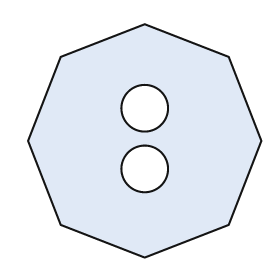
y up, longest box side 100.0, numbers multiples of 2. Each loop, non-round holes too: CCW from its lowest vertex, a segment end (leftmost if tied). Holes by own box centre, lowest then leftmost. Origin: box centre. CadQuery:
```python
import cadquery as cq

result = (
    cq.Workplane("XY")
    .moveTo(0.0, -50.0)
    .lineTo(36.0, -36.0)
    .lineTo(50.0, 0.0)
    .lineTo(36.0, 36.0)
    .lineTo(0.0, 50.0)
    .lineTo(-36.0, 36.0)
    .lineTo(-50.0, 0.0)
    .lineTo(-36.0, -36.0)
    .close()
    .moveTo(0.0, -12.0)
    .circle(10.0)
    .moveTo(0.0, 14.0)
    .circle(10.0)
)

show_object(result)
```